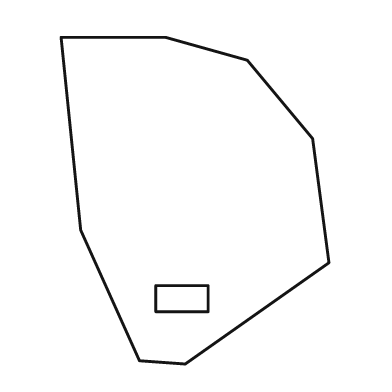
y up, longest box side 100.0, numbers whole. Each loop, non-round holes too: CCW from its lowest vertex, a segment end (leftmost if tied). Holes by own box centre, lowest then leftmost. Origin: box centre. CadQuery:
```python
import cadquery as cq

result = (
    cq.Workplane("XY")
    .moveTo(-3.0, -50.0)
    .lineTo(41.0, -19.0)
    .lineTo(36.0, 19.0)
    .lineTo(16.0, 43.0)
    .lineTo(-9.0, 50.0)
    .lineTo(-41.0, 50.0)
    .lineTo(-35.0, -9.0)
    .lineTo(-17.0, -49.0)
    .close()
    .moveTo(-12.0, -34.0)
    .lineTo(4.0, -34.0)
    .lineTo(4.0, -26.0)
    .lineTo(-12.0, -26.0)
    .close()
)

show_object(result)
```